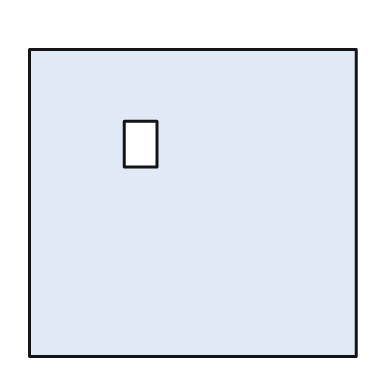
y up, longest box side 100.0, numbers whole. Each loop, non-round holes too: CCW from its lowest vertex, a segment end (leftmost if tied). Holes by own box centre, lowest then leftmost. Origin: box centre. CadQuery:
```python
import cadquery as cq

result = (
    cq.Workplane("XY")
    .moveTo(-50.0, -47.0)
    .lineTo(50.0, -47.0)
    .lineTo(50.0, 47.0)
    .lineTo(-50.0, 47.0)
    .close()
    .moveTo(-21.0, 11.0)
    .lineTo(-11.0, 11.0)
    .lineTo(-11.0, 25.0)
    .lineTo(-21.0, 25.0)
    .close()
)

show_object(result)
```